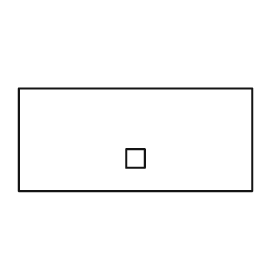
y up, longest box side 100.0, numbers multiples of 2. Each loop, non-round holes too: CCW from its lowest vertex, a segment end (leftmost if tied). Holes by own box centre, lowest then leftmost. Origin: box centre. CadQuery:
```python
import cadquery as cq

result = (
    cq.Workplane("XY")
    .moveTo(-50.0, -22.0)
    .lineTo(50.0, -22.0)
    .lineTo(50.0, 22.0)
    .lineTo(-50.0, 22.0)
    .close()
    .moveTo(-4.0, -12.0)
    .lineTo(4.0, -12.0)
    .lineTo(4.0, -4.0)
    .lineTo(-4.0, -4.0)
    .close()
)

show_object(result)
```